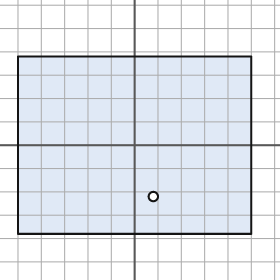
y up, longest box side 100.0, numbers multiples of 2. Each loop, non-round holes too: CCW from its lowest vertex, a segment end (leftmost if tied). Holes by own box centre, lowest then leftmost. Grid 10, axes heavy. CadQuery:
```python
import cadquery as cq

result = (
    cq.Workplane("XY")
    .moveTo(-50.0, -38.0)
    .lineTo(50.0, -38.0)
    .lineTo(50.0, 38.0)
    .lineTo(-50.0, 38.0)
    .close()
    .moveTo(8.0, -22.0)
    .circle(2.0)
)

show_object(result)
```